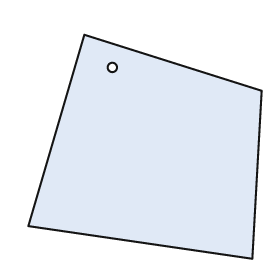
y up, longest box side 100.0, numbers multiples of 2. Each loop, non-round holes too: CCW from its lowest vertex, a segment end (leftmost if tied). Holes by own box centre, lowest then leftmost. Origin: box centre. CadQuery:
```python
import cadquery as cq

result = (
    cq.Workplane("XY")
    .moveTo(46.0, -48.0)
    .lineTo(50.0, 24.0)
    .lineTo(-26.0, 48.0)
    .lineTo(-50.0, -34.0)
    .close()
    .moveTo(-14.0, 34.0)
    .circle(2.0)
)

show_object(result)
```